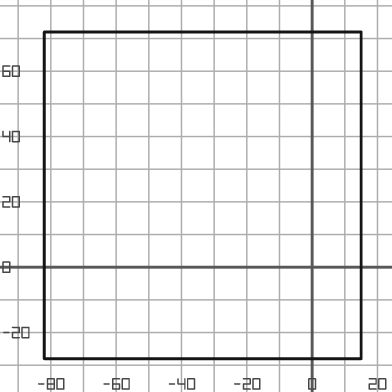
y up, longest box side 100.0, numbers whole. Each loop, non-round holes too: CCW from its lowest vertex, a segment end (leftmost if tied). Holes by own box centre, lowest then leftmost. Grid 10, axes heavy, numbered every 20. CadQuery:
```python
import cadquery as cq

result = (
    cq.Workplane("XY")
    .moveTo(-82.0, -28.0)
    .lineTo(15.0, -28.0)
    .lineTo(15.0, 72.0)
    .lineTo(-82.0, 72.0)
    .close()
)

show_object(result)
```